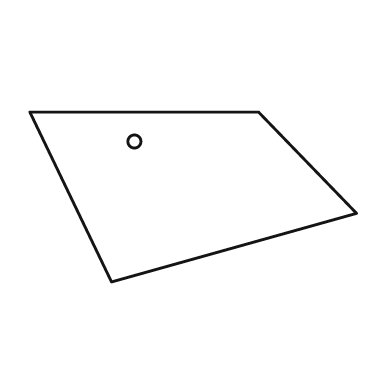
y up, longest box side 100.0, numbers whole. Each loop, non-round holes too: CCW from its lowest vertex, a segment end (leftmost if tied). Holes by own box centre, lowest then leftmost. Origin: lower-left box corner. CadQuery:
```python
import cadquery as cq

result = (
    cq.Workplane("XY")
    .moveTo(25.0, 0.0)
    .lineTo(100.0, 21.0)
    .lineTo(70.0, 52.0)
    .lineTo(0.0, 52.0)
    .close()
    .moveTo(32.0, 43.0)
    .circle(2.0)
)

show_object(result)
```